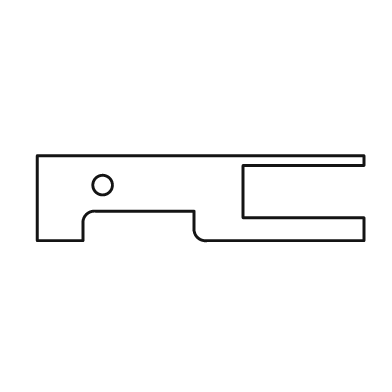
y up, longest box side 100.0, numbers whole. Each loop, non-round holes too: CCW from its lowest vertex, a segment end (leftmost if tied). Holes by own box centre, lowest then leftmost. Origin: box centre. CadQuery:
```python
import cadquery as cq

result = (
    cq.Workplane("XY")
    .moveTo(-50.0, -13.0)
    .lineTo(-36.0, -13.0)
    .lineTo(-36.0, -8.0)
    .threePointArc((-35.0, -5.0), (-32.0, -4.0))
    .lineTo(-2.0, -4.0)
    .lineTo(-2.0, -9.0)
    .threePointArc((-1.0, -12.0), (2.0, -13.0))
    .lineTo(50.0, -13.0)
    .lineTo(50.0, -6.0)
    .lineTo(13.0, -6.0)
    .lineTo(13.0, 10.0)
    .lineTo(50.0, 10.0)
    .lineTo(50.0, 13.0)
    .lineTo(-50.0, 13.0)
    .close()
    .moveTo(-30.0, 4.0)
    .circle(3.0)
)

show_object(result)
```